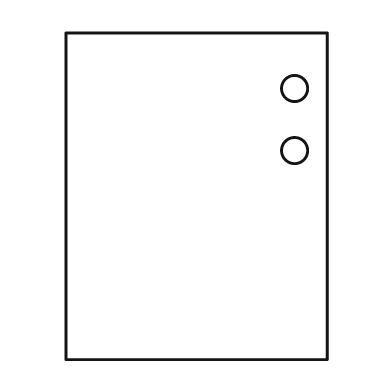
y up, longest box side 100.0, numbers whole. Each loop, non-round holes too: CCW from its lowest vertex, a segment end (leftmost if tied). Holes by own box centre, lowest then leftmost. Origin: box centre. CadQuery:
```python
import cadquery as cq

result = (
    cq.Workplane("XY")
    .moveTo(-40.0, -50.0)
    .lineTo(40.0, -50.0)
    .lineTo(40.0, 50.0)
    .lineTo(-40.0, 50.0)
    .close()
    .moveTo(30.0, 14.0)
    .circle(4.0)
    .moveTo(30.0, 33.0)
    .circle(4.0)
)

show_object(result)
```